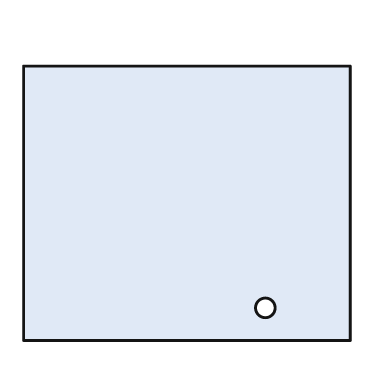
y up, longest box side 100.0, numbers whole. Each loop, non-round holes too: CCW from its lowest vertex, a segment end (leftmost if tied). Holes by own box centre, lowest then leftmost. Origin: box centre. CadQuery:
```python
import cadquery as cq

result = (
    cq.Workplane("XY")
    .moveTo(-50.0, -42.0)
    .lineTo(50.0, -42.0)
    .lineTo(50.0, 42.0)
    .lineTo(-50.0, 42.0)
    .close()
    .moveTo(24.0, -32.0)
    .circle(3.0)
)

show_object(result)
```